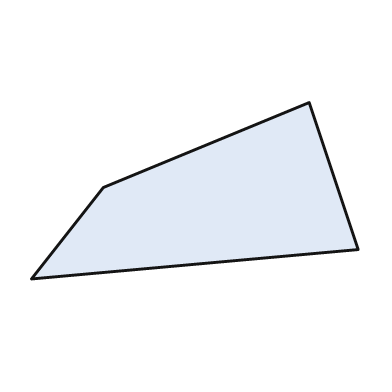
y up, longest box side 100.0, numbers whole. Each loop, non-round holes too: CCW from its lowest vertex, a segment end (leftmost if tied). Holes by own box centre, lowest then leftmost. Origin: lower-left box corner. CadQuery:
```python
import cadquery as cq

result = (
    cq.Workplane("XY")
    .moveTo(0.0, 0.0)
    .lineTo(100.0, 9.0)
    .lineTo(85.0, 54.0)
    .lineTo(22.0, 28.0)
    .close()
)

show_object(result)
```